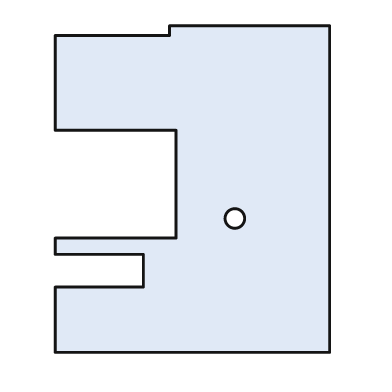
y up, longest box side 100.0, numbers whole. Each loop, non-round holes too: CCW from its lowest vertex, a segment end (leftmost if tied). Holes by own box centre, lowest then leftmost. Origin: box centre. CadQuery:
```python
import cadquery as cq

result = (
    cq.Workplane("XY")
    .moveTo(-42.0, -50.0)
    .lineTo(42.0, -50.0)
    .lineTo(42.0, 50.0)
    .lineTo(-7.0, 50.0)
    .lineTo(-7.0, 47.0)
    .lineTo(-42.0, 47.0)
    .lineTo(-42.0, 18.0)
    .lineTo(-5.0, 18.0)
    .lineTo(-5.0, -15.0)
    .lineTo(-42.0, -15.0)
    .lineTo(-42.0, -20.0)
    .lineTo(-15.0, -20.0)
    .lineTo(-15.0, -30.0)
    .lineTo(-42.0, -30.0)
    .close()
    .moveTo(13.0, -9.0)
    .circle(3.0)
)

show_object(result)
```